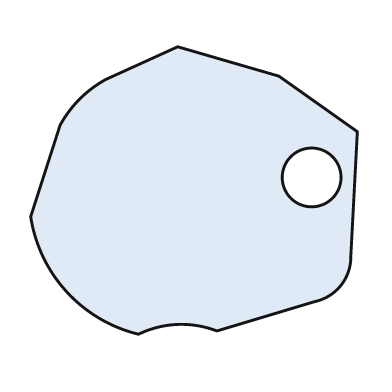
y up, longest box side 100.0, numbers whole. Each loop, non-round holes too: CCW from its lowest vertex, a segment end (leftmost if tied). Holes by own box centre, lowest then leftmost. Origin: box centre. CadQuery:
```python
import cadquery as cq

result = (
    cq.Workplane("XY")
    .moveTo(-17.0, -44.0)
    .threePointArc((-5.0, -41.0), (7.0, -43.0))
    .lineTo(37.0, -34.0)
    .threePointArc((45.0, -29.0), (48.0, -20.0))
    .lineTo(50.0, 18.0)
    .lineTo(26.0, 35.0)
    .lineTo(-5.0, 44.0)
    .lineTo(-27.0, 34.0)
    .threePointArc((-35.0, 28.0), (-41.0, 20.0))
    .lineTo(-50.0, -8.0)
    .threePointArc((-39.0, -31.0), (-17.0, -44.0))
    .close()
    .moveTo(36.0, 4.0)
    .circle(9.0)
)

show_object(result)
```